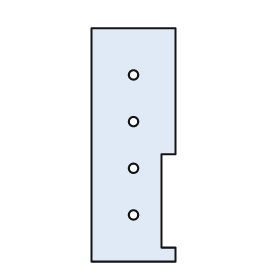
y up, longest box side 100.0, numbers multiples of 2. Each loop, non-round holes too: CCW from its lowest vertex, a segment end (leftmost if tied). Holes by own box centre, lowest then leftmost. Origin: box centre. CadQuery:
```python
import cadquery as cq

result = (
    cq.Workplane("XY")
    .moveTo(-18.0, -50.0)
    .lineTo(18.0, -50.0)
    .lineTo(18.0, -44.0)
    .lineTo(12.0, -44.0)
    .lineTo(12.0, -4.0)
    .lineTo(18.0, -4.0)
    .lineTo(18.0, 50.0)
    .lineTo(-18.0, 50.0)
    .close()
    .moveTo(0.0, -30.0)
    .circle(2.0)
    .moveTo(0.0, -10.0)
    .circle(2.0)
    .moveTo(0.0, 10.0)
    .circle(2.0)
    .moveTo(0.0, 30.0)
    .circle(2.0)
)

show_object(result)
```